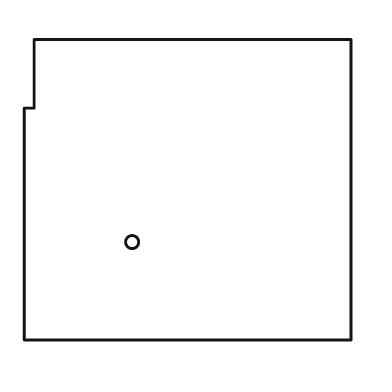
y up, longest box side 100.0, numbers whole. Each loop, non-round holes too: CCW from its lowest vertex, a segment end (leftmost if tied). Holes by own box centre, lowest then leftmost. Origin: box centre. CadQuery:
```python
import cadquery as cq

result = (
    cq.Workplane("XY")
    .moveTo(-50.0, -46.0)
    .lineTo(50.0, -46.0)
    .lineTo(50.0, 46.0)
    .lineTo(-47.0, 46.0)
    .lineTo(-47.0, 25.0)
    .lineTo(-50.0, 25.0)
    .close()
    .moveTo(-17.0, -16.0)
    .circle(2.0)
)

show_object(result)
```